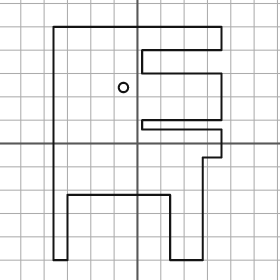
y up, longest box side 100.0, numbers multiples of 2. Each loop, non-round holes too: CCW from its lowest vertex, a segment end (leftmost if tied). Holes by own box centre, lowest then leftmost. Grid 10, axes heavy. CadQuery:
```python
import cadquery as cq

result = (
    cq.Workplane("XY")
    .moveTo(-36.0, -50.0)
    .lineTo(-30.0, -50.0)
    .lineTo(-30.0, -22.0)
    .lineTo(14.0, -22.0)
    .lineTo(14.0, -50.0)
    .lineTo(28.0, -50.0)
    .lineTo(28.0, -6.0)
    .lineTo(36.0, -6.0)
    .lineTo(36.0, 6.0)
    .lineTo(2.0, 6.0)
    .lineTo(2.0, 10.0)
    .lineTo(36.0, 10.0)
    .lineTo(36.0, 30.0)
    .lineTo(2.0, 30.0)
    .lineTo(2.0, 40.0)
    .lineTo(36.0, 40.0)
    .lineTo(36.0, 50.0)
    .lineTo(-36.0, 50.0)
    .close()
    .moveTo(-6.0, 24.0)
    .circle(2.0)
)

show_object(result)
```